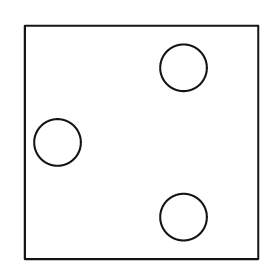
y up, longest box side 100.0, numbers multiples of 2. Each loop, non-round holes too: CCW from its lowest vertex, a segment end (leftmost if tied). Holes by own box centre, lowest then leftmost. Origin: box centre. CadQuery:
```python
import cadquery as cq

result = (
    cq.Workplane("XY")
    .moveTo(-50.0, -50.0)
    .lineTo(50.0, -50.0)
    .lineTo(50.0, 50.0)
    .lineTo(-50.0, 50.0)
    .close()
    .moveTo(18.0, -32.0)
    .circle(10.0)
    .moveTo(-36.0, 0.0)
    .circle(10.0)
    .moveTo(18.0, 32.0)
    .circle(10.0)
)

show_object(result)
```